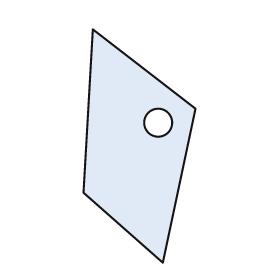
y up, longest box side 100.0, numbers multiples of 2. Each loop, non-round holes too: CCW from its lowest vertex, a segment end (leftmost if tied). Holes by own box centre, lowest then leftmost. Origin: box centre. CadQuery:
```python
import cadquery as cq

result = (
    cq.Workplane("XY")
    .moveTo(10.0, -50.0)
    .lineTo(24.0, 16.0)
    .lineTo(-20.0, 50.0)
    .lineTo(-24.0, -20.0)
    .close()
    .moveTo(8.0, 10.0)
    .circle(6.0)
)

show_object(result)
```